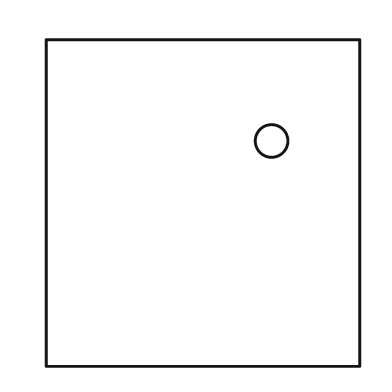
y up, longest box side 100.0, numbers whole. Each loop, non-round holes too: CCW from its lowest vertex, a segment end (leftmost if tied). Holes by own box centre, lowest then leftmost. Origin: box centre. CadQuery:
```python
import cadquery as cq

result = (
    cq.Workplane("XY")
    .moveTo(-48.0, -50.0)
    .lineTo(48.0, -50.0)
    .lineTo(48.0, 50.0)
    .lineTo(-48.0, 50.0)
    .close()
    .moveTo(21.0, 19.0)
    .circle(5.0)
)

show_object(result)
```